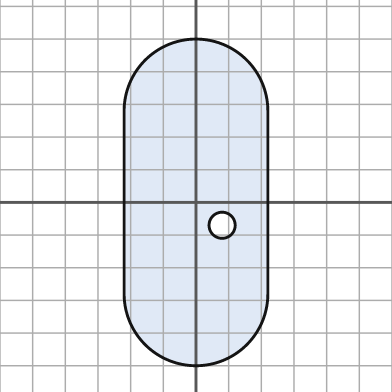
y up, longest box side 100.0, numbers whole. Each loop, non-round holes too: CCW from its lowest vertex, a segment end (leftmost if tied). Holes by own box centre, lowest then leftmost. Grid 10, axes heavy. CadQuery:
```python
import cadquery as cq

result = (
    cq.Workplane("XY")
    .moveTo(-22.0, -28.0)
    .threePointArc((0.0, -50.0), (22.0, -28.0))
    .lineTo(22.0, 28.0)
    .threePointArc((0.0, 50.0), (-22.0, 28.0))
    .close()
    .moveTo(8.0, -7.0)
    .circle(4.0)
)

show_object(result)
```